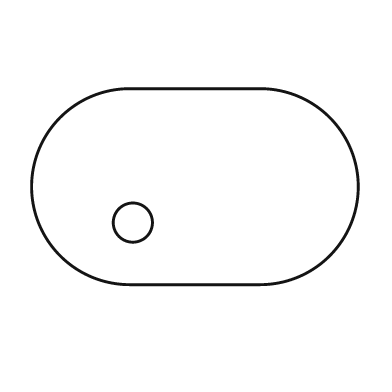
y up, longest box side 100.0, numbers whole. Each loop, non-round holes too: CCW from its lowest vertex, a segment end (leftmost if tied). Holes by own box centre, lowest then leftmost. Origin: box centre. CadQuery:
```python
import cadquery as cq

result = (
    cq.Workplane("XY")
    .moveTo(-20.0, -30.0)
    .lineTo(20.0, -30.0)
    .threePointArc((50.0, 0.0), (20.0, 30.0))
    .lineTo(-20.0, 30.0)
    .threePointArc((-50.0, 0.0), (-20.0, -30.0))
    .close()
    .moveTo(-19.0, -11.0)
    .circle(6.0)
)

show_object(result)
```